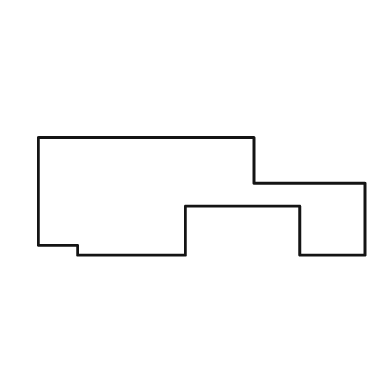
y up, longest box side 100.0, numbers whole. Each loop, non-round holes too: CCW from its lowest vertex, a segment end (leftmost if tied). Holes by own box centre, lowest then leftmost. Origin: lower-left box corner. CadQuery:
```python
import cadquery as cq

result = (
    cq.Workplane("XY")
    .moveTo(12.0, 0.0)
    .lineTo(45.0, 0.0)
    .lineTo(45.0, 15.0)
    .lineTo(80.0, 15.0)
    .lineTo(80.0, 0.0)
    .lineTo(100.0, 0.0)
    .lineTo(100.0, 22.0)
    .lineTo(66.0, 22.0)
    .lineTo(66.0, 36.0)
    .lineTo(0.0, 36.0)
    .lineTo(0.0, 3.0)
    .lineTo(12.0, 3.0)
    .close()
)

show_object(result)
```